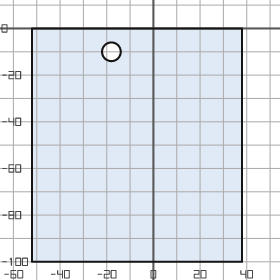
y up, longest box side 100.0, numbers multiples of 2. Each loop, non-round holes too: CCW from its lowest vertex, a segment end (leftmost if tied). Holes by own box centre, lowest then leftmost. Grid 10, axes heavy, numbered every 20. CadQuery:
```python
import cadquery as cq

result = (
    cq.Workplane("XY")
    .moveTo(-52.0, -100.0)
    .lineTo(38.0, -100.0)
    .lineTo(38.0, 0.0)
    .lineTo(-52.0, 0.0)
    .close()
    .moveTo(-18.0, -10.0)
    .circle(4.0)
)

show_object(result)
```